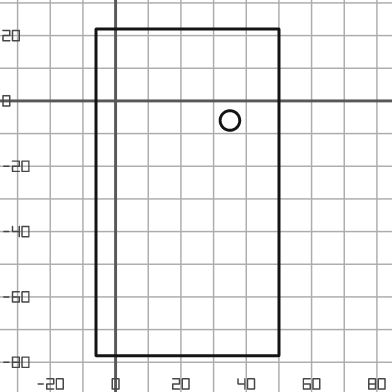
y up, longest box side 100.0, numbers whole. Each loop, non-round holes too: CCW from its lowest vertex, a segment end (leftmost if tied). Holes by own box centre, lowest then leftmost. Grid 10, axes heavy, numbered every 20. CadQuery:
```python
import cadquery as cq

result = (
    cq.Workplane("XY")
    .moveTo(-6.0, -78.0)
    .lineTo(50.0, -78.0)
    .lineTo(50.0, 22.0)
    .lineTo(-6.0, 22.0)
    .close()
    .moveTo(35.0, -6.0)
    .circle(3.0)
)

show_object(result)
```